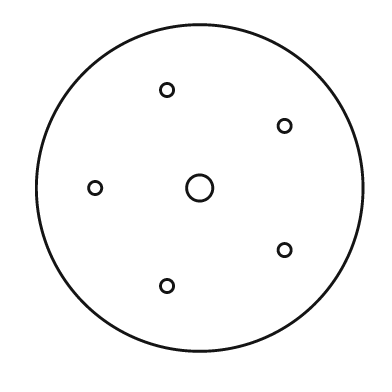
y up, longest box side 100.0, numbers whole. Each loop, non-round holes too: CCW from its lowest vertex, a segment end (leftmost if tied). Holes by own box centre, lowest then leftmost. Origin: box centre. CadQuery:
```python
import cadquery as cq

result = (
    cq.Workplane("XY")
    .moveTo(0.0, 0.0)
    .circle(50.0)
    .moveTo(-10.0, -30.0)
    .circle(2.0)
    .moveTo(26.0, -19.0)
    .circle(2.0)
    .moveTo(-32.0, 0.0)
    .circle(2.0)
    .moveTo(0.0, 0.0)
    .circle(4.0)
    .moveTo(26.0, 19.0)
    .circle(2.0)
    .moveTo(-10.0, 30.0)
    .circle(2.0)
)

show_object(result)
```